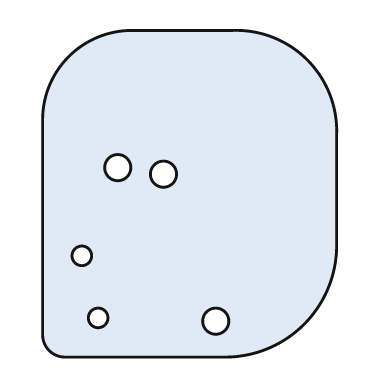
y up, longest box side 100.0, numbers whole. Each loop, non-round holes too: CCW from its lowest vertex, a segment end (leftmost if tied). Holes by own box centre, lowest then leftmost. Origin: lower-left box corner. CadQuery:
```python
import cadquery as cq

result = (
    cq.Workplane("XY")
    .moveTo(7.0, 0.0)
    .lineTo(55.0, 0.0)
    .threePointArc((80.0, 10.0), (90.0, 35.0))
    .lineTo(90.0, 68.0)
    .threePointArc((81.0, 91.0), (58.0, 100.0))
    .lineTo(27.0, 100.0)
    .threePointArc((8.0, 92.0), (0.0, 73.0))
    .lineTo(0.0, 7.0)
    .threePointArc((2.0, 2.0), (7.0, 0.0))
    .close()
    .moveTo(53.0, 11.0)
    .circle(4.0)
    .moveTo(17.0, 12.0)
    .circle(3.0)
    .moveTo(12.0, 31.0)
    .circle(3.0)
    .moveTo(37.0, 56.0)
    .circle(4.0)
    .moveTo(23.0, 58.0)
    .circle(4.0)
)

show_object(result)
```